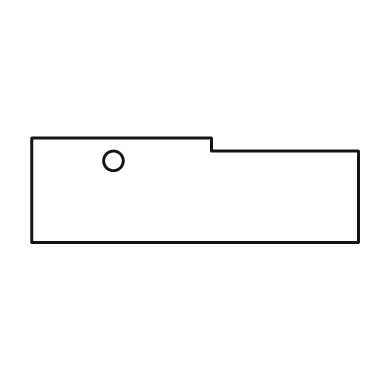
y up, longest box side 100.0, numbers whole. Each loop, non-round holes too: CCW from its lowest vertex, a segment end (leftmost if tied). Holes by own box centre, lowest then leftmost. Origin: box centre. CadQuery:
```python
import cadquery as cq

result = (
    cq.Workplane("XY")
    .moveTo(-50.0, -16.0)
    .lineTo(50.0, -16.0)
    .lineTo(50.0, 12.0)
    .lineTo(5.0, 12.0)
    .lineTo(5.0, 16.0)
    .lineTo(-50.0, 16.0)
    .close()
    .moveTo(-25.0, 9.0)
    .circle(3.0)
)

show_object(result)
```